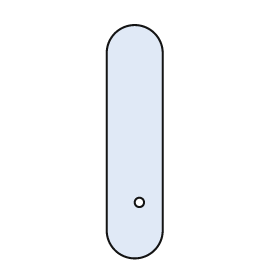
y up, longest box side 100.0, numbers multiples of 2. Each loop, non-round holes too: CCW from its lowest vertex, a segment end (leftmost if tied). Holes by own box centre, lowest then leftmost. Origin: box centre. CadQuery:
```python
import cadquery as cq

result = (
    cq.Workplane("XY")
    .moveTo(-12.0, -38.0)
    .threePointArc((0.0, -50.0), (12.0, -38.0))
    .lineTo(12.0, 38.0)
    .threePointArc((0.0, 50.0), (-12.0, 38.0))
    .close()
    .moveTo(2.0, -26.0)
    .circle(2.0)
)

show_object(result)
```